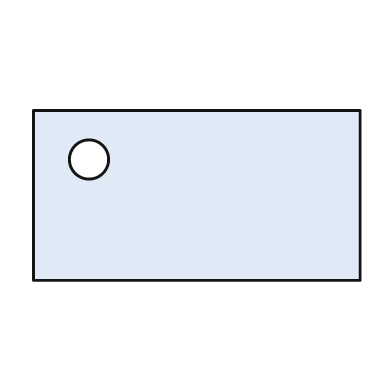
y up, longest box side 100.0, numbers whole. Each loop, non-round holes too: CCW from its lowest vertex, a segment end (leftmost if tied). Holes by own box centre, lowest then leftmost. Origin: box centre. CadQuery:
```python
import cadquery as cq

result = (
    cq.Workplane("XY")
    .moveTo(-50.0, -26.0)
    .lineTo(50.0, -26.0)
    .lineTo(50.0, 26.0)
    .lineTo(-50.0, 26.0)
    .close()
    .moveTo(-33.0, 11.0)
    .circle(6.0)
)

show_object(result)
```